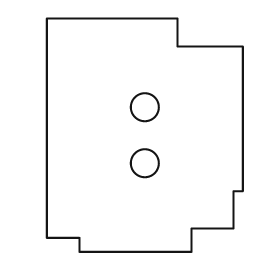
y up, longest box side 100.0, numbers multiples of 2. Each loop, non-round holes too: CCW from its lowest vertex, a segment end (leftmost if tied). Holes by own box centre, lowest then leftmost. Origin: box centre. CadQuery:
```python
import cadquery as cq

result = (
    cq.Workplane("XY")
    .moveTo(-28.0, -50.0)
    .lineTo(20.0, -50.0)
    .lineTo(20.0, -40.0)
    .lineTo(38.0, -40.0)
    .lineTo(38.0, -24.0)
    .lineTo(42.0, -24.0)
    .lineTo(42.0, 38.0)
    .lineTo(14.0, 38.0)
    .lineTo(14.0, 50.0)
    .lineTo(-42.0, 50.0)
    .lineTo(-42.0, -44.0)
    .lineTo(-28.0, -44.0)
    .close()
    .moveTo(0.0, -12.0)
    .circle(6.0)
    .moveTo(0.0, 12.0)
    .circle(6.0)
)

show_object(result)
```